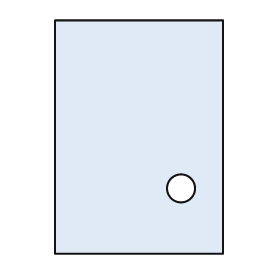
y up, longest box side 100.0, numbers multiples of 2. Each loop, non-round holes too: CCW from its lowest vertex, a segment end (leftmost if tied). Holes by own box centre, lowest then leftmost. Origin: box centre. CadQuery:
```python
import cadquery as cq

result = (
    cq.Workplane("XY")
    .moveTo(-36.0, -50.0)
    .lineTo(36.0, -50.0)
    .lineTo(36.0, 50.0)
    .lineTo(-36.0, 50.0)
    .close()
    .moveTo(18.0, -22.0)
    .circle(6.0)
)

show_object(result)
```